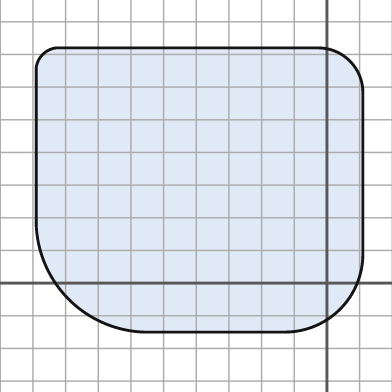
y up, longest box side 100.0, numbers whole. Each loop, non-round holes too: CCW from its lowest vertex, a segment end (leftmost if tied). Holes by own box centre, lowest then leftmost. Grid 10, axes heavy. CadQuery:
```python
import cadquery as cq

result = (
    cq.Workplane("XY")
    .moveTo(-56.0, -15.0)
    .lineTo(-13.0, -15.0)
    .threePointArc((4.0, -8.0), (11.0, 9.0))
    .lineTo(11.0, 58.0)
    .threePointArc((7.0, 68.0), (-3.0, 72.0))
    .lineTo(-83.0, 72.0)
    .threePointArc((-87.0, 70.0), (-89.0, 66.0))
    .lineTo(-89.0, 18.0)
    .threePointArc((-79.0, -5.0), (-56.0, -15.0))
    .close()
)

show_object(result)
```